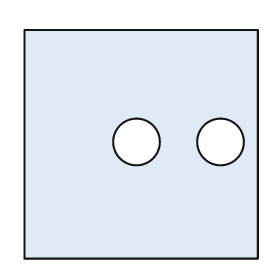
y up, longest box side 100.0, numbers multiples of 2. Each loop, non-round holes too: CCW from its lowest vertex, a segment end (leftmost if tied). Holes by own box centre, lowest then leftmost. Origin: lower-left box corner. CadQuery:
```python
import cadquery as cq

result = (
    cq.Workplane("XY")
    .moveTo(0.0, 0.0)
    .lineTo(100.0, 0.0)
    .lineTo(100.0, 98.0)
    .lineTo(0.0, 98.0)
    .close()
    .moveTo(48.0, 50.0)
    .circle(10.0)
    .moveTo(84.0, 50.0)
    .circle(10.0)
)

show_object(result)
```